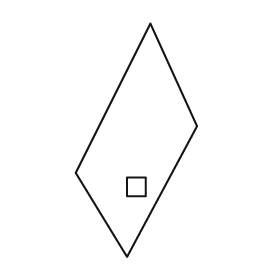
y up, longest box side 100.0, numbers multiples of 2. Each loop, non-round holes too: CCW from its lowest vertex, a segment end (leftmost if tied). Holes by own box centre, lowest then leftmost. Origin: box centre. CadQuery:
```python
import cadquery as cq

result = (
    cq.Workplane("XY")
    .moveTo(-4.0, -50.0)
    .lineTo(26.0, 6.0)
    .lineTo(6.0, 50.0)
    .lineTo(-26.0, -14.0)
    .close()
    .moveTo(-4.0, -24.0)
    .lineTo(4.0, -24.0)
    .lineTo(4.0, -16.0)
    .lineTo(-4.0, -16.0)
    .close()
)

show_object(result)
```